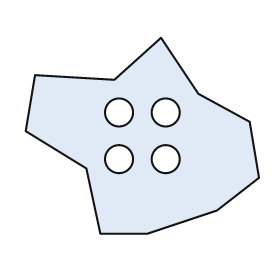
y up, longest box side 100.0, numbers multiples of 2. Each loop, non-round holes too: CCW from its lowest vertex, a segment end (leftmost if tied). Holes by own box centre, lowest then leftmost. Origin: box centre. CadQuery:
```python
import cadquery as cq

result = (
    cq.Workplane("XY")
    .moveTo(-18.0, -42.0)
    .lineTo(2.0, -42.0)
    .lineTo(32.0, -32.0)
    .lineTo(50.0, -18.0)
    .lineTo(46.0, 6.0)
    .lineTo(24.0, 18.0)
    .lineTo(8.0, 42.0)
    .lineTo(-12.0, 24.0)
    .lineTo(-46.0, 26.0)
    .lineTo(-50.0, 2.0)
    .lineTo(-24.0, -14.0)
    .close()
    .moveTo(-10.0, -10.0)
    .circle(6.0)
    .moveTo(10.0, -10.0)
    .circle(6.0)
    .moveTo(-10.0, 10.0)
    .circle(6.0)
    .moveTo(10.0, 10.0)
    .circle(6.0)
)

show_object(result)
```